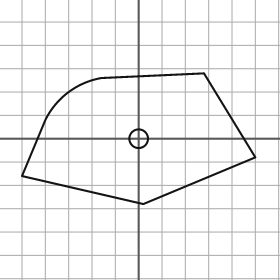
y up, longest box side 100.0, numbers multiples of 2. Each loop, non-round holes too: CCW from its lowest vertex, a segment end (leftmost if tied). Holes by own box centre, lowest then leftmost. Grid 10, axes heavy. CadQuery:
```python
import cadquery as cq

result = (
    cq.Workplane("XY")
    .moveTo(2.0, -28.0)
    .lineTo(50.0, -8.0)
    .lineTo(28.0, 28.0)
    .lineTo(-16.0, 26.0)
    .threePointArc((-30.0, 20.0), (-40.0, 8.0))
    .lineTo(-50.0, -16.0)
    .close()
    .moveTo(0.0, 0.0)
    .circle(4.0)
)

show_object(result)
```